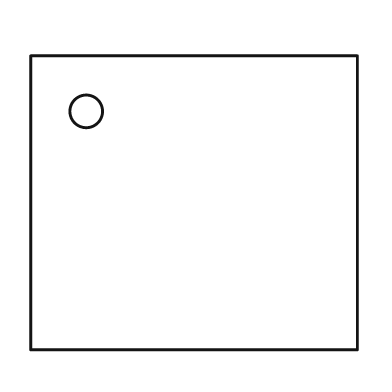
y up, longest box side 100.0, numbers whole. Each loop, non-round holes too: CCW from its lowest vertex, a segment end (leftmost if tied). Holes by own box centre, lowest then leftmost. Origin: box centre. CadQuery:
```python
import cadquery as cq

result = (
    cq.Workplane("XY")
    .moveTo(-50.0, -45.0)
    .lineTo(50.0, -45.0)
    .lineTo(50.0, 45.0)
    .lineTo(-50.0, 45.0)
    .close()
    .moveTo(-33.0, 28.0)
    .circle(5.0)
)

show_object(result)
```